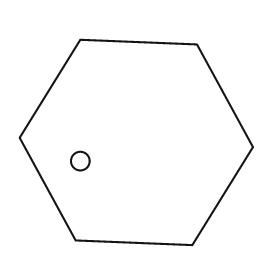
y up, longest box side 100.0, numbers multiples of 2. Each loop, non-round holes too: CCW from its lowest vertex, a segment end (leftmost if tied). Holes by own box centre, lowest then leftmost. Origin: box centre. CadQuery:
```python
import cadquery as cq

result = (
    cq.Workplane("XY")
    .moveTo(24.0, -44.0)
    .lineTo(50.0, -2.0)
    .lineTo(26.0, 42.0)
    .lineTo(-24.0, 44.0)
    .lineTo(-50.0, 2.0)
    .lineTo(-26.0, -42.0)
    .close()
    .moveTo(-24.0, -8.0)
    .circle(4.0)
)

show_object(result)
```